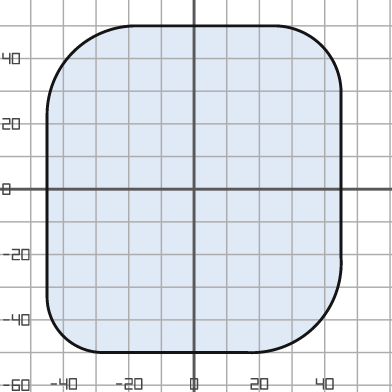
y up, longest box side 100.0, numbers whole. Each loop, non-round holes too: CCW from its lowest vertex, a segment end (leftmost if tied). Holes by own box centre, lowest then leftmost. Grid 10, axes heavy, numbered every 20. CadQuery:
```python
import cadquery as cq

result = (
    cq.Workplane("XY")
    .moveTo(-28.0, -50.0)
    .lineTo(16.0, -50.0)
    .threePointArc((37.0, -42.0), (45.0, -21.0))
    .lineTo(45.0, 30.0)
    .threePointArc((39.0, 44.0), (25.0, 50.0))
    .lineTo(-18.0, 50.0)
    .threePointArc((-37.0, 42.0), (-45.0, 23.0))
    .lineTo(-45.0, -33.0)
    .threePointArc((-40.0, -45.0), (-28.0, -50.0))
    .close()
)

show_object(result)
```